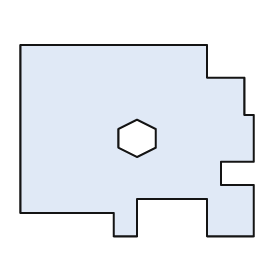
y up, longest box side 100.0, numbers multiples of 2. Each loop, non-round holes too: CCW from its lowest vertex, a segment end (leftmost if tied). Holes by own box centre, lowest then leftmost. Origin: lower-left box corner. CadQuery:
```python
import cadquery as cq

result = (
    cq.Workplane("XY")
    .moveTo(40.0, 0.0)
    .lineTo(50.0, 0.0)
    .lineTo(50.0, 16.0)
    .lineTo(80.0, 16.0)
    .lineTo(80.0, 0.0)
    .lineTo(100.0, 0.0)
    .lineTo(100.0, 22.0)
    .lineTo(86.0, 22.0)
    .lineTo(86.0, 32.0)
    .lineTo(100.0, 32.0)
    .lineTo(100.0, 52.0)
    .lineTo(96.0, 52.0)
    .lineTo(96.0, 68.0)
    .lineTo(80.0, 68.0)
    .lineTo(80.0, 82.0)
    .lineTo(0.0, 82.0)
    .lineTo(0.0, 10.0)
    .lineTo(40.0, 10.0)
    .close()
    .moveTo(50.0, 34.0)
    .lineTo(58.0, 38.0)
    .lineTo(58.0, 46.0)
    .lineTo(50.0, 50.0)
    .lineTo(42.0, 46.0)
    .lineTo(42.0, 38.0)
    .close()
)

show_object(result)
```